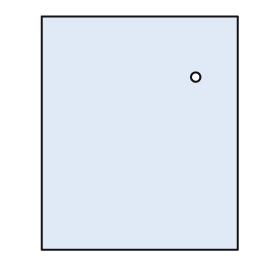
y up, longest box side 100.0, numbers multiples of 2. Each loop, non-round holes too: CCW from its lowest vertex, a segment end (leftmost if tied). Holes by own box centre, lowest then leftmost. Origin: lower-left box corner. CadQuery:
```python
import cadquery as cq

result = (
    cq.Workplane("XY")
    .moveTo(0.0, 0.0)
    .lineTo(84.0, 0.0)
    .lineTo(84.0, 100.0)
    .lineTo(0.0, 100.0)
    .close()
    .moveTo(66.0, 74.0)
    .circle(2.0)
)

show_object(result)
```